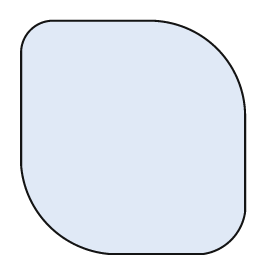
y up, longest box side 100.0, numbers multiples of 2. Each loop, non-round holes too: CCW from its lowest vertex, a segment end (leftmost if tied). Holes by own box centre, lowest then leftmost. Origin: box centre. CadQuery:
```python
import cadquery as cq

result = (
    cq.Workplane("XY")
    .moveTo(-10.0, -50.0)
    .lineTo(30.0, -50.0)
    .threePointArc((42.0, -44.0), (48.0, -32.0))
    .lineTo(48.0, 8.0)
    .threePointArc((36.0, 38.0), (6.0, 50.0))
    .lineTo(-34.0, 50.0)
    .threePointArc((-44.0, 46.0), (-48.0, 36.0))
    .lineTo(-48.0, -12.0)
    .threePointArc((-36.0, -38.0), (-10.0, -50.0))
    .close()
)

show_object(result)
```